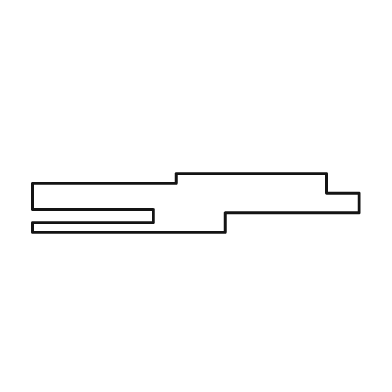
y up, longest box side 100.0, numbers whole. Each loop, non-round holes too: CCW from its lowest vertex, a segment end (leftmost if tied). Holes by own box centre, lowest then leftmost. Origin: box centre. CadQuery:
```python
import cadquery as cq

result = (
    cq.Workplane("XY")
    .moveTo(-50.0, -9.0)
    .lineTo(9.0, -9.0)
    .lineTo(9.0, -3.0)
    .lineTo(50.0, -3.0)
    .lineTo(50.0, 3.0)
    .lineTo(40.0, 3.0)
    .lineTo(40.0, 9.0)
    .lineTo(-6.0, 9.0)
    .lineTo(-6.0, 6.0)
    .lineTo(-50.0, 6.0)
    .lineTo(-50.0, -2.0)
    .lineTo(-13.0, -2.0)
    .lineTo(-13.0, -6.0)
    .lineTo(-50.0, -6.0)
    .close()
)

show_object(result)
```